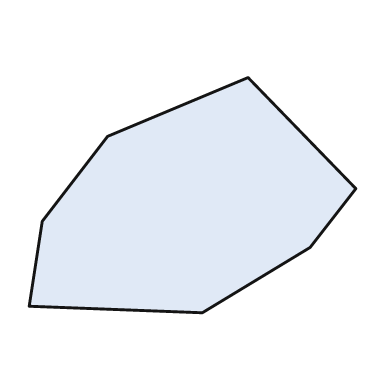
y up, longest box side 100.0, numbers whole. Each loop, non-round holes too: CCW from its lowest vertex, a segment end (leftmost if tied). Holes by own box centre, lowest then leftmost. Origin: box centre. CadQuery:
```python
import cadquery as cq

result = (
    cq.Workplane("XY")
    .moveTo(3.0, -36.0)
    .lineTo(36.0, -16.0)
    .lineTo(50.0, 2.0)
    .lineTo(17.0, 36.0)
    .lineTo(-26.0, 18.0)
    .lineTo(-46.0, -8.0)
    .lineTo(-50.0, -34.0)
    .close()
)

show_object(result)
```